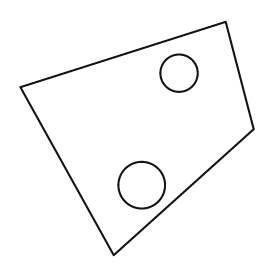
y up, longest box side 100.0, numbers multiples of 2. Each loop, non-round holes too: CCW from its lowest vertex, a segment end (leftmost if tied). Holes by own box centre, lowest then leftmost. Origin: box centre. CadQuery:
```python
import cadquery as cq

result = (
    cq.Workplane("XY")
    .moveTo(-10.0, -50.0)
    .lineTo(50.0, 4.0)
    .lineTo(38.0, 50.0)
    .lineTo(-50.0, 22.0)
    .close()
    .moveTo(2.0, -20.0)
    .circle(10.0)
    .moveTo(18.0, 28.0)
    .circle(8.0)
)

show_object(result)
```